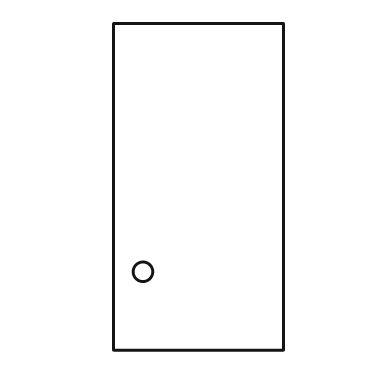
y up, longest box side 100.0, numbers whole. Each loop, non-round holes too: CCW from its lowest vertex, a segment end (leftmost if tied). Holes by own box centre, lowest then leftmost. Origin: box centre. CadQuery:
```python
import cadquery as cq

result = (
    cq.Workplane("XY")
    .moveTo(-26.0, -50.0)
    .lineTo(26.0, -50.0)
    .lineTo(26.0, 50.0)
    .lineTo(-26.0, 50.0)
    .close()
    .moveTo(-17.0, -26.0)
    .circle(3.0)
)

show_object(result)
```